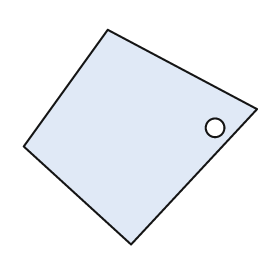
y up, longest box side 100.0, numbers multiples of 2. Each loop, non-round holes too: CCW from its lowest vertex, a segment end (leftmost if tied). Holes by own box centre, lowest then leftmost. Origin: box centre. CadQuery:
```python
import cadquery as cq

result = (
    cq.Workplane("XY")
    .moveTo(-4.0, -46.0)
    .lineTo(50.0, 12.0)
    .lineTo(-14.0, 46.0)
    .lineTo(-50.0, -4.0)
    .close()
    .moveTo(32.0, 4.0)
    .circle(4.0)
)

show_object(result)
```